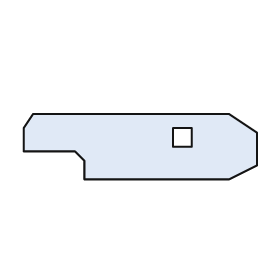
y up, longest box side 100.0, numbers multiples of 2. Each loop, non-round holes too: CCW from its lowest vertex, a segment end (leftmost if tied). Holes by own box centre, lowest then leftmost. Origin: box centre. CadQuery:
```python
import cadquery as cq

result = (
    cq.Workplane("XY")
    .moveTo(-24.0, -14.0)
    .lineTo(38.0, -14.0)
    .lineTo(50.0, -8.0)
    .lineTo(50.0, 6.0)
    .lineTo(38.0, 14.0)
    .lineTo(-46.0, 14.0)
    .lineTo(-50.0, 8.0)
    .lineTo(-50.0, -2.0)
    .lineTo(-28.0, -2.0)
    .lineTo(-24.0, -6.0)
    .close()
    .moveTo(14.0, 0.0)
    .lineTo(22.0, 0.0)
    .lineTo(22.0, 8.0)
    .lineTo(14.0, 8.0)
    .close()
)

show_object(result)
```